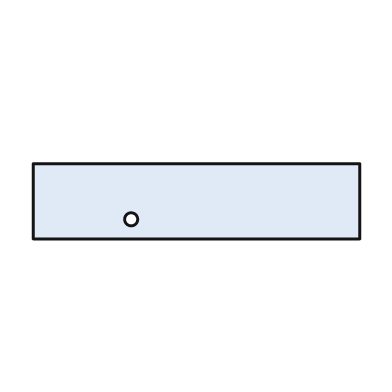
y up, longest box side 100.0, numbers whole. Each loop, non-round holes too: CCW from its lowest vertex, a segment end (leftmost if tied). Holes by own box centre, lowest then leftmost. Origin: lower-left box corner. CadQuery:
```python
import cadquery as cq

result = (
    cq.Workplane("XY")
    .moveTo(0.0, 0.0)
    .lineTo(100.0, 0.0)
    .lineTo(100.0, 23.0)
    .lineTo(0.0, 23.0)
    .close()
    .moveTo(30.0, 6.0)
    .circle(2.0)
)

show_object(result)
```